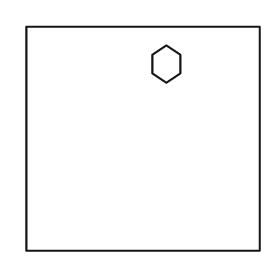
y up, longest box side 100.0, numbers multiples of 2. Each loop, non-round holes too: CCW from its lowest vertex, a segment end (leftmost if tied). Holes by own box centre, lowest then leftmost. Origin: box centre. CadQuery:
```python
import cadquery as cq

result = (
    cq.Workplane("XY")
    .moveTo(-50.0, -48.0)
    .lineTo(50.0, -48.0)
    .lineTo(50.0, 48.0)
    .lineTo(-50.0, 48.0)
    .close()
    .moveTo(10.0, 24.0)
    .lineTo(16.0, 28.0)
    .lineTo(16.0, 36.0)
    .lineTo(10.0, 40.0)
    .lineTo(4.0, 36.0)
    .lineTo(4.0, 28.0)
    .close()
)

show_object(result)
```